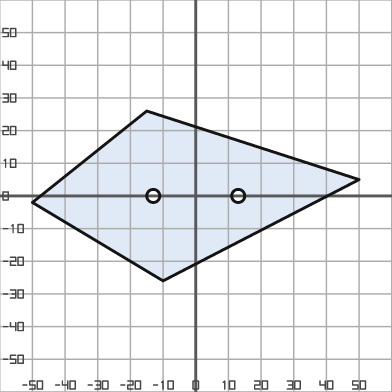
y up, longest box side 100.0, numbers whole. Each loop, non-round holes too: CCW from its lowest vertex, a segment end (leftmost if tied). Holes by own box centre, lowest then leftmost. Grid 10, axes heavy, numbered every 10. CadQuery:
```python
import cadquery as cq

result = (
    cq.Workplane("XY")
    .moveTo(-10.0, -26.0)
    .lineTo(50.0, 5.0)
    .lineTo(-15.0, 26.0)
    .lineTo(-50.0, -2.0)
    .close()
    .moveTo(-13.0, 0.0)
    .circle(2.0)
    .moveTo(13.0, 0.0)
    .circle(2.0)
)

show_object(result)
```